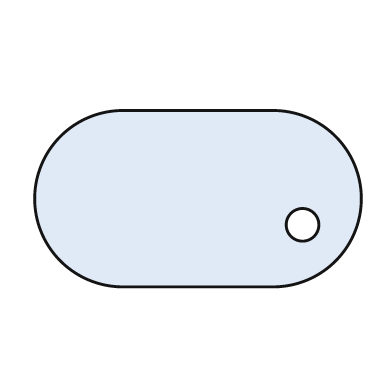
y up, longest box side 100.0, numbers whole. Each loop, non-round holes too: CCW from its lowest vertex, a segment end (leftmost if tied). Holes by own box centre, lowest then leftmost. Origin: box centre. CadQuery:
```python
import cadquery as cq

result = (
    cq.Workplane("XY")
    .moveTo(-23.0, -27.0)
    .lineTo(23.0, -27.0)
    .threePointArc((50.0, 0.0), (23.0, 27.0))
    .lineTo(-23.0, 27.0)
    .threePointArc((-50.0, 0.0), (-23.0, -27.0))
    .close()
    .moveTo(32.0, -8.0)
    .circle(5.0)
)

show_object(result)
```